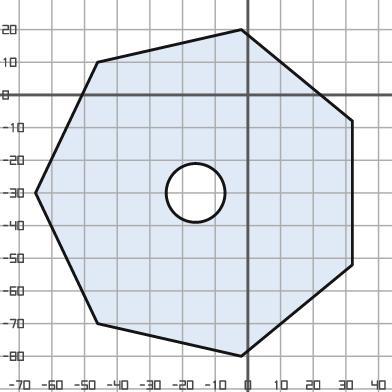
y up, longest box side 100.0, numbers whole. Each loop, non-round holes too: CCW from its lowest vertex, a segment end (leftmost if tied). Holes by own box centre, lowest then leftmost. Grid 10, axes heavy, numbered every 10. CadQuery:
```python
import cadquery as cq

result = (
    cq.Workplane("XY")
    .moveTo(-2.0, -80.0)
    .lineTo(32.0, -52.0)
    .lineTo(32.0, -8.0)
    .lineTo(-2.0, 20.0)
    .lineTo(-46.0, 10.0)
    .lineTo(-65.0, -30.0)
    .lineTo(-46.0, -70.0)
    .close()
    .moveTo(-16.0, -30.0)
    .circle(9.0)
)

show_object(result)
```